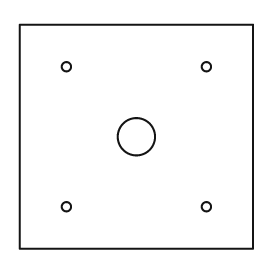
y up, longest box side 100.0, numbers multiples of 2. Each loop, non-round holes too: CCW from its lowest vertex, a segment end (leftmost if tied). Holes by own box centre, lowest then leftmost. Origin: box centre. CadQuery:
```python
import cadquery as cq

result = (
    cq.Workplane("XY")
    .moveTo(-50.0, -48.0)
    .lineTo(50.0, -48.0)
    .lineTo(50.0, 48.0)
    .lineTo(-50.0, 48.0)
    .close()
    .moveTo(-30.0, -30.0)
    .circle(2.0)
    .moveTo(30.0, -30.0)
    .circle(2.0)
    .moveTo(0.0, 0.0)
    .circle(8.0)
    .moveTo(-30.0, 30.0)
    .circle(2.0)
    .moveTo(30.0, 30.0)
    .circle(2.0)
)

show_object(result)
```